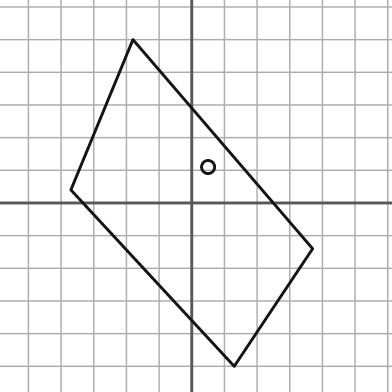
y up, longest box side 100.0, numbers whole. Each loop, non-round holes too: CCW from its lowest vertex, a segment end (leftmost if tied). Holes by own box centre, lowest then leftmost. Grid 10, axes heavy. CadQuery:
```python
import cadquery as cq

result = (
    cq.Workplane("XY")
    .moveTo(13.0, -50.0)
    .lineTo(37.0, -14.0)
    .lineTo(-18.0, 50.0)
    .lineTo(-37.0, 4.0)
    .close()
    .moveTo(5.0, 11.0)
    .circle(2.0)
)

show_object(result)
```